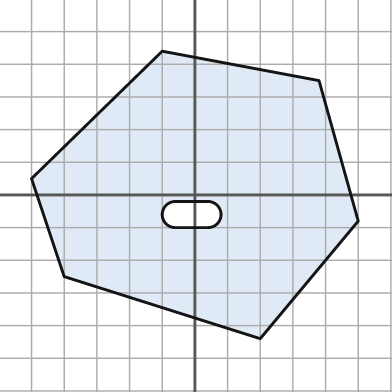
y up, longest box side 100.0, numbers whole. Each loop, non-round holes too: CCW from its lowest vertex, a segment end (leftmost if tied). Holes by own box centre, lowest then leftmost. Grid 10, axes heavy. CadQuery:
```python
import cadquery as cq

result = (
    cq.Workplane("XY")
    .moveTo(20.0, -44.0)
    .lineTo(50.0, -8.0)
    .lineTo(38.0, 35.0)
    .lineTo(-10.0, 44.0)
    .lineTo(-50.0, 5.0)
    .lineTo(-40.0, -25.0)
    .close()
    .moveTo(-6.0, -10.0)
    .lineTo(4.0, -10.0)
    .threePointArc((8.0, -6.0), (4.0, -2.0))
    .lineTo(-6.0, -2.0)
    .threePointArc((-10.0, -6.0), (-6.0, -10.0))
    .close()
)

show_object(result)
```